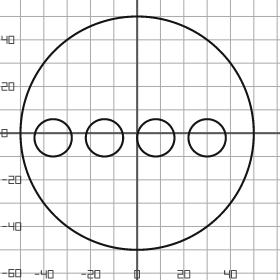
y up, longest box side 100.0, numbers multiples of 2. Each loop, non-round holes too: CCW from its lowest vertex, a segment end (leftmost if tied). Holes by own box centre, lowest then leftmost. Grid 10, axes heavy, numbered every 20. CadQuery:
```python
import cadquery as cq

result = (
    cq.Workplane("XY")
    .moveTo(0.0, 0.0)
    .circle(50.0)
    .moveTo(-36.0, -2.0)
    .circle(8.0)
    .moveTo(-14.0, -2.0)
    .circle(8.0)
    .moveTo(8.0, -2.0)
    .circle(8.0)
    .moveTo(30.0, -2.0)
    .circle(8.0)
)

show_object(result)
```